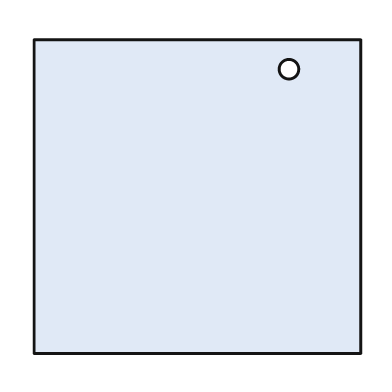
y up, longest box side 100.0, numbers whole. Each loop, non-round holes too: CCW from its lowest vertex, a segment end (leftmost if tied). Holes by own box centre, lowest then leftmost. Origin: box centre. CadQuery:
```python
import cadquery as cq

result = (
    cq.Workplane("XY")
    .moveTo(-50.0, -48.0)
    .lineTo(50.0, -48.0)
    .lineTo(50.0, 48.0)
    .lineTo(-50.0, 48.0)
    .close()
    .moveTo(28.0, 39.0)
    .circle(3.0)
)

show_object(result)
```